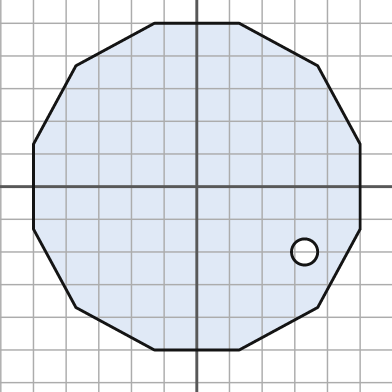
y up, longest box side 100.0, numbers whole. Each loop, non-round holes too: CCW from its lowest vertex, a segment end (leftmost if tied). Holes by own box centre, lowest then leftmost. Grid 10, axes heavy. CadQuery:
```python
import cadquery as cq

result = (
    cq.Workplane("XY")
    .moveTo(-13.0, -50.0)
    .lineTo(13.0, -50.0)
    .lineTo(37.0, -37.0)
    .lineTo(50.0, -13.0)
    .lineTo(50.0, 13.0)
    .lineTo(37.0, 37.0)
    .lineTo(13.0, 50.0)
    .lineTo(-13.0, 50.0)
    .lineTo(-37.0, 37.0)
    .lineTo(-50.0, 13.0)
    .lineTo(-50.0, -13.0)
    .lineTo(-37.0, -37.0)
    .close()
    .moveTo(33.0, -20.0)
    .circle(4.0)
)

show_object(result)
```